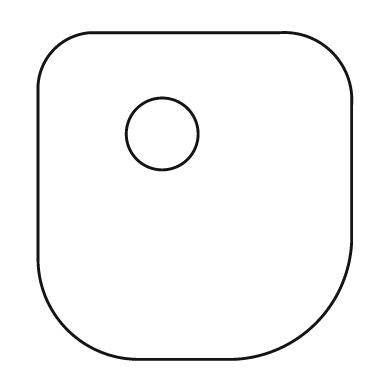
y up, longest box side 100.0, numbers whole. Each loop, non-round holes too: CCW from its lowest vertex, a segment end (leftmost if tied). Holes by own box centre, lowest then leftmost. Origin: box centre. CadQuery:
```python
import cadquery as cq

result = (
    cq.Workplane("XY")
    .moveTo(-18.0, -50.0)
    .lineTo(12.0, -50.0)
    .threePointArc((37.0, -39.0), (48.0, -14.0))
    .lineTo(48.0, 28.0)
    .threePointArc((42.0, 44.0), (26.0, 50.0))
    .lineTo(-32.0, 50.0)
    .threePointArc((-43.0, 45.0), (-48.0, 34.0))
    .lineTo(-48.0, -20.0)
    .threePointArc((-39.0, -41.0), (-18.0, -50.0))
    .close()
    .moveTo(-10.0, 19.0)
    .circle(11.0)
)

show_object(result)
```